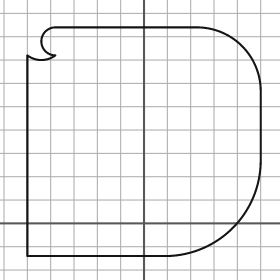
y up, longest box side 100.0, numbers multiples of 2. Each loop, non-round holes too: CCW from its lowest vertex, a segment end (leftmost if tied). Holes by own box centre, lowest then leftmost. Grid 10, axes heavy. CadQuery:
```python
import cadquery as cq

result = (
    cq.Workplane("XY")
    .moveTo(-50.0, -14.0)
    .lineTo(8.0, -14.0)
    .threePointArc((38.0, -2.0), (50.0, 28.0))
    .lineTo(50.0, 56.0)
    .threePointArc((42.0, 76.0), (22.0, 84.0))
    .lineTo(-38.0, 84.0)
    .threePointArc((-44.0, 78.0), (-38.0, 72.0))
    .threePointArc((-44.0, 70.0), (-50.0, 72.0))
    .close()
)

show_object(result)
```